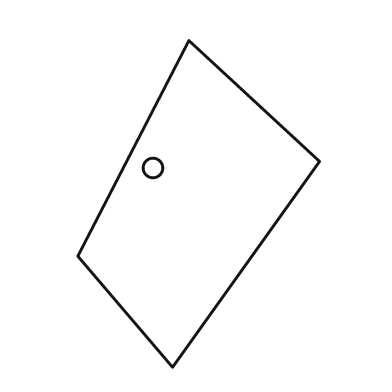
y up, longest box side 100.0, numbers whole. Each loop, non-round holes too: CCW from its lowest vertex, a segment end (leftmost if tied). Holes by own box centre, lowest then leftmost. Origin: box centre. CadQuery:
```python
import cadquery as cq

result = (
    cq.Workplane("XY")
    .moveTo(-8.0, -50.0)
    .lineTo(37.0, 13.0)
    .lineTo(-3.0, 50.0)
    .lineTo(-37.0, -16.0)
    .close()
    .moveTo(-14.0, 11.0)
    .circle(3.0)
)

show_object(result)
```